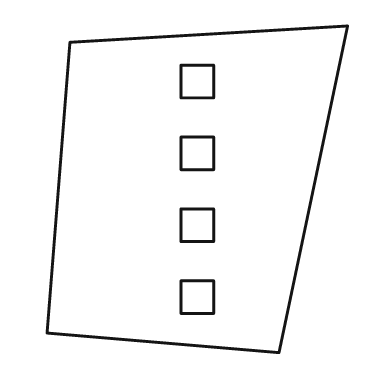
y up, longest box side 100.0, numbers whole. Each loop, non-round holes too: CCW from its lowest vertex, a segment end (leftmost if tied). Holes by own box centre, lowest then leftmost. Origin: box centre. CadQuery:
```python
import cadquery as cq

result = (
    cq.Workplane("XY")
    .moveTo(25.0, -50.0)
    .lineTo(46.0, 50.0)
    .lineTo(-39.0, 45.0)
    .lineTo(-46.0, -44.0)
    .close()
    .moveTo(-5.0, -38.0)
    .lineTo(5.0, -38.0)
    .lineTo(5.0, -28.0)
    .lineTo(-5.0, -28.0)
    .close()
    .moveTo(-5.0, -16.0)
    .lineTo(5.0, -16.0)
    .lineTo(5.0, -6.0)
    .lineTo(-5.0, -6.0)
    .close()
    .moveTo(-5.0, 6.0)
    .lineTo(5.0, 6.0)
    .lineTo(5.0, 16.0)
    .lineTo(-5.0, 16.0)
    .close()
    .moveTo(-5.0, 28.0)
    .lineTo(5.0, 28.0)
    .lineTo(5.0, 38.0)
    .lineTo(-5.0, 38.0)
    .close()
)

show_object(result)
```